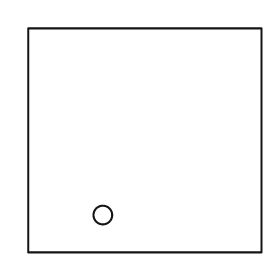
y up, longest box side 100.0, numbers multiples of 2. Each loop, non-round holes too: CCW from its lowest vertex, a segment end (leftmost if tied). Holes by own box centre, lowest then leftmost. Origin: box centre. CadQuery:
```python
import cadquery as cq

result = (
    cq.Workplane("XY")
    .moveTo(-50.0, -48.0)
    .lineTo(50.0, -48.0)
    .lineTo(50.0, 48.0)
    .lineTo(-50.0, 48.0)
    .close()
    .moveTo(-18.0, -32.0)
    .circle(4.0)
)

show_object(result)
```